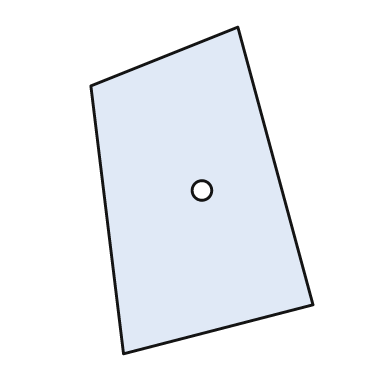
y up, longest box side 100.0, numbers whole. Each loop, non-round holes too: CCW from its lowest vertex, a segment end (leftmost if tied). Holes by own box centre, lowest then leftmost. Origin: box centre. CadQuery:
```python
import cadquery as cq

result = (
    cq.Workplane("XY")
    .moveTo(-24.0, -50.0)
    .lineTo(34.0, -35.0)
    .lineTo(11.0, 50.0)
    .lineTo(-34.0, 32.0)
    .close()
    .moveTo(0.0, 0.0)
    .circle(3.0)
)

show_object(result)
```